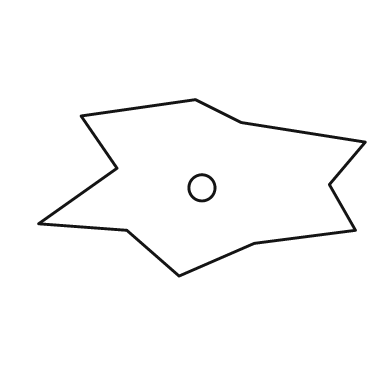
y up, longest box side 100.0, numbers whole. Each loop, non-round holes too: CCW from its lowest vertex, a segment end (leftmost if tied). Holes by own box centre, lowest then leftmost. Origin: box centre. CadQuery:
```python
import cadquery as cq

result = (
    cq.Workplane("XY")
    .moveTo(-7.0, -27.0)
    .lineTo(16.0, -17.0)
    .lineTo(47.0, -13.0)
    .lineTo(39.0, 1.0)
    .lineTo(50.0, 14.0)
    .lineTo(12.0, 20.0)
    .lineTo(-2.0, 27.0)
    .lineTo(-37.0, 22.0)
    .lineTo(-26.0, 6.0)
    .lineTo(-50.0, -11.0)
    .lineTo(-23.0, -13.0)
    .close()
    .moveTo(0.0, 0.0)
    .circle(4.0)
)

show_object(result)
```